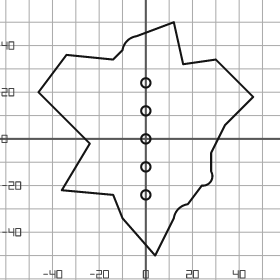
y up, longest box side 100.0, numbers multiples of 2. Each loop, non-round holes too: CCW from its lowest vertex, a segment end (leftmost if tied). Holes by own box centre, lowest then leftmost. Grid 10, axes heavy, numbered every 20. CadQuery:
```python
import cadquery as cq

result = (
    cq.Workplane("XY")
    .moveTo(4.0, -50.0)
    .lineTo(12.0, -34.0)
    .threePointArc((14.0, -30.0), (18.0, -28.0))
    .lineTo(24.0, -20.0)
    .threePointArc((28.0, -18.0), (28.0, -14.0))
    .lineTo(28.0, -6.0)
    .lineTo(34.0, 6.0)
    .lineTo(46.0, 18.0)
    .lineTo(30.0, 34.0)
    .lineTo(16.0, 32.0)
    .lineTo(12.0, 50.0)
    .lineTo(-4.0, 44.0)
    .threePointArc((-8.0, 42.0), (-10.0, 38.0))
    .lineTo(-14.0, 34.0)
    .lineTo(-34.0, 36.0)
    .lineTo(-46.0, 20.0)
    .lineTo(-24.0, -2.0)
    .lineTo(-36.0, -22.0)
    .lineTo(-14.0, -24.0)
    .lineTo(-10.0, -34.0)
    .close()
    .moveTo(0.0, -24.0)
    .circle(2.0)
    .moveTo(0.0, -12.0)
    .circle(2.0)
    .moveTo(0.0, 0.0)
    .circle(2.0)
    .moveTo(0.0, 12.0)
    .circle(2.0)
    .moveTo(0.0, 24.0)
    .circle(2.0)
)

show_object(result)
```